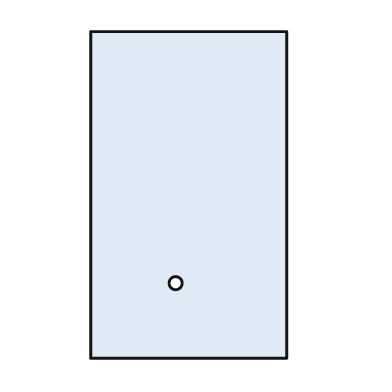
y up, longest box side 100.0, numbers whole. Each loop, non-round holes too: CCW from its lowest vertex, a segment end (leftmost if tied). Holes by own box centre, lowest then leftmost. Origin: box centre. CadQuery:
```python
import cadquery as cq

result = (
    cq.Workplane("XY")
    .moveTo(-30.0, -50.0)
    .lineTo(30.0, -50.0)
    .lineTo(30.0, 50.0)
    .lineTo(-30.0, 50.0)
    .close()
    .moveTo(-4.0, -27.0)
    .circle(2.0)
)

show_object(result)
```